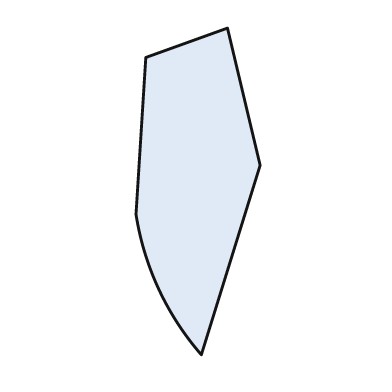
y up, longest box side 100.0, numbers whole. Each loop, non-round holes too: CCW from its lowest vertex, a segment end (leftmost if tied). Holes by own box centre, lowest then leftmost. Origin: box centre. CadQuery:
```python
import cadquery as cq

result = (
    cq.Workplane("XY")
    .moveTo(1.0, -50.0)
    .lineTo(19.0, 8.0)
    .lineTo(9.0, 50.0)
    .lineTo(-16.0, 41.0)
    .lineTo(-19.0, -7.0)
    .threePointArc((-12.0, -30.0), (1.0, -50.0))
    .close()
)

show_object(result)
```